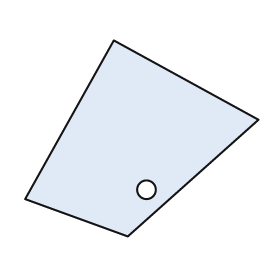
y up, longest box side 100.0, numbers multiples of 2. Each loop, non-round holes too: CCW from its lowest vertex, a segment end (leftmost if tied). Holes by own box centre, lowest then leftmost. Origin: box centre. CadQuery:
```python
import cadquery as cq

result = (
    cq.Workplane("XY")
    .moveTo(-6.0, -42.0)
    .lineTo(50.0, 8.0)
    .lineTo(-12.0, 42.0)
    .lineTo(-50.0, -26.0)
    .close()
    .moveTo(2.0, -22.0)
    .circle(4.0)
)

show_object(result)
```